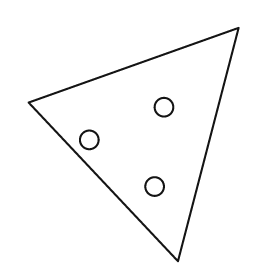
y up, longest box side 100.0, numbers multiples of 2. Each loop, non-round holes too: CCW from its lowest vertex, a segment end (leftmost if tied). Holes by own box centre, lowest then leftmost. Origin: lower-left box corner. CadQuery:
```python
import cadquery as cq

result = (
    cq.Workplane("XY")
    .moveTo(64.0, 0.0)
    .lineTo(90.0, 100.0)
    .lineTo(0.0, 68.0)
    .close()
    .moveTo(54.0, 32.0)
    .circle(4.0)
    .moveTo(26.0, 52.0)
    .circle(4.0)
    .moveTo(58.0, 66.0)
    .circle(4.0)
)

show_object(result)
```